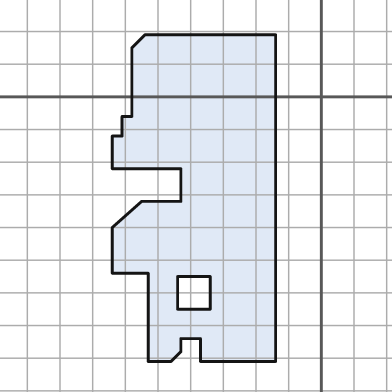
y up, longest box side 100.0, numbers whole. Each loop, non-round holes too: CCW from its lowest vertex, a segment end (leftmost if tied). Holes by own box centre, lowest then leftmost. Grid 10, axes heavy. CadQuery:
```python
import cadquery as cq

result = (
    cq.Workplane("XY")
    .moveTo(-53.0, -81.0)
    .lineTo(-46.0, -81.0)
    .lineTo(-43.0, -78.0)
    .lineTo(-43.0, -74.0)
    .lineTo(-37.0, -74.0)
    .lineTo(-37.0, -81.0)
    .lineTo(-14.0, -81.0)
    .lineTo(-14.0, 19.0)
    .lineTo(-54.0, 19.0)
    .lineTo(-58.0, 15.0)
    .lineTo(-58.0, -6.0)
    .lineTo(-61.0, -6.0)
    .lineTo(-61.0, -12.0)
    .lineTo(-64.0, -12.0)
    .lineTo(-64.0, -22.0)
    .lineTo(-43.0, -22.0)
    .lineTo(-43.0, -32.0)
    .lineTo(-55.0, -32.0)
    .lineTo(-64.0, -40.0)
    .lineTo(-64.0, -54.0)
    .lineTo(-53.0, -54.0)
    .close()
    .moveTo(-44.0, -65.0)
    .lineTo(-34.0, -65.0)
    .lineTo(-34.0, -55.0)
    .lineTo(-44.0, -55.0)
    .close()
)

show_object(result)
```